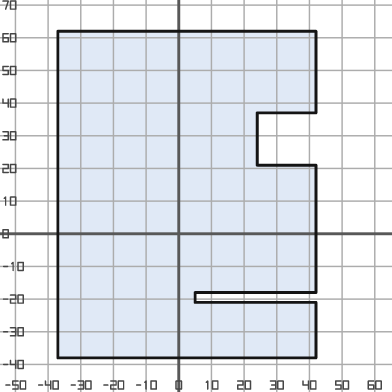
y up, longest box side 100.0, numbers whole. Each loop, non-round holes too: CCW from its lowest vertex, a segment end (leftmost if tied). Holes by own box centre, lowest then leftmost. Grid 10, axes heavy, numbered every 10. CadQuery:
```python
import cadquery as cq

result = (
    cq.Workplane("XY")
    .moveTo(-37.0, -38.0)
    .lineTo(42.0, -38.0)
    .lineTo(42.0, -21.0)
    .lineTo(5.0, -21.0)
    .lineTo(5.0, -18.0)
    .lineTo(42.0, -18.0)
    .lineTo(42.0, 21.0)
    .lineTo(24.0, 21.0)
    .lineTo(24.0, 37.0)
    .lineTo(42.0, 37.0)
    .lineTo(42.0, 62.0)
    .lineTo(-37.0, 62.0)
    .close()
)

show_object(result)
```